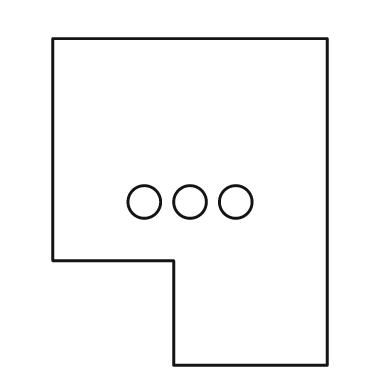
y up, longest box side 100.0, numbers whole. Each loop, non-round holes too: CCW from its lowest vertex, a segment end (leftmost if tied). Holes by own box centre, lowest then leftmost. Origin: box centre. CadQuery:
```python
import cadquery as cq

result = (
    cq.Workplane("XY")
    .moveTo(-5.0, -50.0)
    .lineTo(42.0, -50.0)
    .lineTo(42.0, 50.0)
    .lineTo(-42.0, 50.0)
    .lineTo(-42.0, -18.0)
    .lineTo(-5.0, -18.0)
    .close()
    .moveTo(-14.0, 0.0)
    .circle(5.0)
    .moveTo(0.0, 0.0)
    .circle(5.0)
    .moveTo(14.0, 0.0)
    .circle(5.0)
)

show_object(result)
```